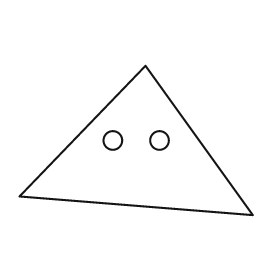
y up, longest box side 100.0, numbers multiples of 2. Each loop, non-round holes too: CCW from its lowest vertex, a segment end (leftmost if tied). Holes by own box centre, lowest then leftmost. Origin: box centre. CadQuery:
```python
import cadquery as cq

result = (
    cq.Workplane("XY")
    .moveTo(50.0, -32.0)
    .lineTo(4.0, 32.0)
    .lineTo(-50.0, -24.0)
    .close()
    .moveTo(-10.0, 0.0)
    .circle(4.0)
    .moveTo(10.0, 0.0)
    .circle(4.0)
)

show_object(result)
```